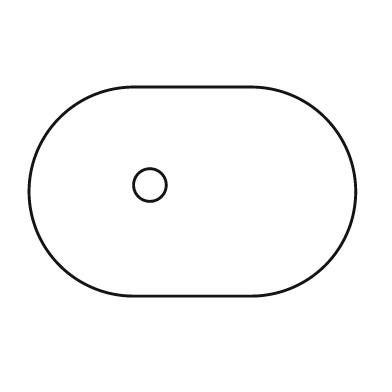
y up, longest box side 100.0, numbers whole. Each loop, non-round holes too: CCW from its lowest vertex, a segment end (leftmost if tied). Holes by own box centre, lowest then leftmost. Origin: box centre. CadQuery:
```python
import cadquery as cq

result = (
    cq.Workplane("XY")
    .moveTo(-18.0, -32.0)
    .lineTo(18.0, -32.0)
    .threePointArc((50.0, 0.0), (18.0, 32.0))
    .lineTo(-18.0, 32.0)
    .threePointArc((-50.0, 0.0), (-18.0, -32.0))
    .close()
    .moveTo(-13.0, 2.0)
    .circle(5.0)
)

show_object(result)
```